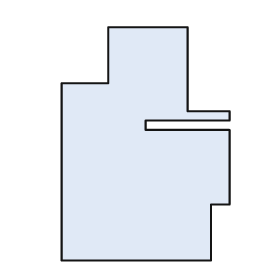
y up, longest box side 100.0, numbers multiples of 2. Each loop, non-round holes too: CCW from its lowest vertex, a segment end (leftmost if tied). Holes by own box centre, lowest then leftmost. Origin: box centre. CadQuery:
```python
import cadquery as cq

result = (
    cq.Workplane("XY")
    .moveTo(-36.0, -50.0)
    .lineTo(28.0, -50.0)
    .lineTo(28.0, -26.0)
    .lineTo(36.0, -26.0)
    .lineTo(36.0, 6.0)
    .lineTo(0.0, 6.0)
    .lineTo(0.0, 10.0)
    .lineTo(36.0, 10.0)
    .lineTo(36.0, 14.0)
    .lineTo(18.0, 14.0)
    .lineTo(18.0, 50.0)
    .lineTo(-16.0, 50.0)
    .lineTo(-16.0, 26.0)
    .lineTo(-36.0, 26.0)
    .close()
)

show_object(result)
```